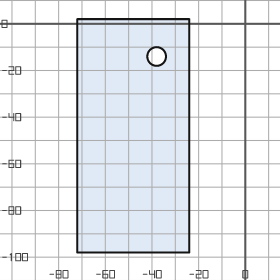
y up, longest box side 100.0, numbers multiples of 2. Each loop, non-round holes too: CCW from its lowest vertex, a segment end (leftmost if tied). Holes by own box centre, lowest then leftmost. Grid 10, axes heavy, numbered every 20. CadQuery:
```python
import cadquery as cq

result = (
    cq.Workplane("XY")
    .moveTo(-72.0, -98.0)
    .lineTo(-24.0, -98.0)
    .lineTo(-24.0, 2.0)
    .lineTo(-72.0, 2.0)
    .close()
    .moveTo(-38.0, -14.0)
    .circle(4.0)
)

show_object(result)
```